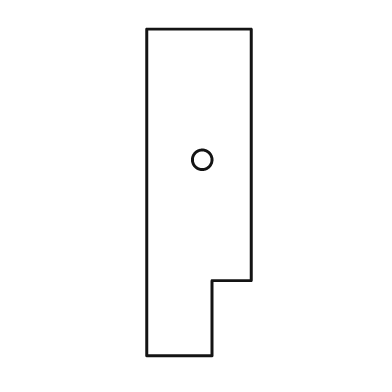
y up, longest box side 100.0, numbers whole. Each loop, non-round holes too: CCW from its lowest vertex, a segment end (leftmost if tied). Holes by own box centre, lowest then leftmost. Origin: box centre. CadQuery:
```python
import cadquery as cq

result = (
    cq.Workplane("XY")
    .moveTo(-16.0, -50.0)
    .lineTo(4.0, -50.0)
    .lineTo(4.0, -27.0)
    .lineTo(16.0, -27.0)
    .lineTo(16.0, 50.0)
    .lineTo(-16.0, 50.0)
    .close()
    .moveTo(1.0, 10.0)
    .circle(3.0)
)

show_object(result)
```